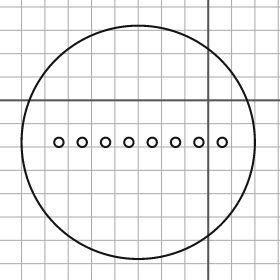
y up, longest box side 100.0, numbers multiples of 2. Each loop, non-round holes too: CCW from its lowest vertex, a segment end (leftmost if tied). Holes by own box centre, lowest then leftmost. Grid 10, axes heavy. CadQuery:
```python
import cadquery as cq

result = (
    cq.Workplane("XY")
    .moveTo(-30.0, -18.0)
    .circle(50.0)
    .moveTo(-64.0, -18.0)
    .circle(2.0)
    .moveTo(-54.0, -18.0)
    .circle(2.0)
    .moveTo(-44.0, -18.0)
    .circle(2.0)
    .moveTo(-34.0, -18.0)
    .circle(2.0)
    .moveTo(-24.0, -18.0)
    .circle(2.0)
    .moveTo(-14.0, -18.0)
    .circle(2.0)
    .moveTo(-4.0, -18.0)
    .circle(2.0)
    .moveTo(6.0, -18.0)
    .circle(2.0)
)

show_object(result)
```